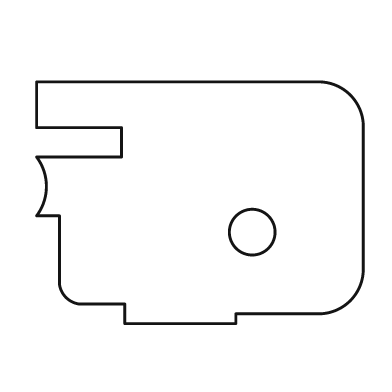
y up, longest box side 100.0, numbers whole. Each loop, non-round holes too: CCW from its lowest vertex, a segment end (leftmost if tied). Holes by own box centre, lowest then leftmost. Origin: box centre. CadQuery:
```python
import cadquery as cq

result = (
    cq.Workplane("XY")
    .moveTo(-23.0, -37.0)
    .lineTo(11.0, -37.0)
    .lineTo(11.0, -34.0)
    .lineTo(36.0, -34.0)
    .threePointArc((46.0, -30.0), (50.0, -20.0))
    .lineTo(50.0, 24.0)
    .threePointArc((46.0, 33.0), (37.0, 37.0))
    .lineTo(-50.0, 37.0)
    .lineTo(-50.0, 23.0)
    .lineTo(-24.0, 23.0)
    .lineTo(-24.0, 14.0)
    .lineTo(-50.0, 14.0)
    .threePointArc((-47.0, 5.0), (-50.0, -4.0))
    .lineTo(-43.0, -4.0)
    .lineTo(-43.0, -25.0)
    .threePointArc((-41.0, -29.0), (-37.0, -31.0))
    .lineTo(-23.0, -31.0)
    .close()
    .moveTo(16.0, -9.0)
    .circle(7.0)
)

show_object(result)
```